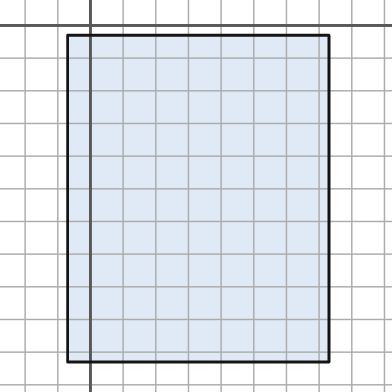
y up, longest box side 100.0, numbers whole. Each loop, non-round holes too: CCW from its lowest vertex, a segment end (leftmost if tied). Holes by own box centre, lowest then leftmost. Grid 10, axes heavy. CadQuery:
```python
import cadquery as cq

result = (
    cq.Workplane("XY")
    .moveTo(-7.0, -103.0)
    .lineTo(73.0, -103.0)
    .lineTo(73.0, -3.0)
    .lineTo(-7.0, -3.0)
    .close()
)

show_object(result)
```